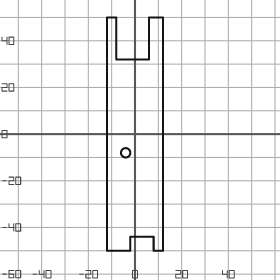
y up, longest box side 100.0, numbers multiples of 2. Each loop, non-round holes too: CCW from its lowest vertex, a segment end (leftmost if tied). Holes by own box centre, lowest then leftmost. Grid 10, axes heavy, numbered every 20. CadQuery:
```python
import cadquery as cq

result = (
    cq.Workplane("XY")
    .moveTo(-12.0, -50.0)
    .lineTo(-2.0, -50.0)
    .lineTo(-2.0, -44.0)
    .lineTo(8.0, -44.0)
    .lineTo(8.0, -50.0)
    .lineTo(12.0, -50.0)
    .lineTo(12.0, 50.0)
    .lineTo(6.0, 50.0)
    .lineTo(6.0, 32.0)
    .lineTo(-8.0, 32.0)
    .lineTo(-8.0, 50.0)
    .lineTo(-12.0, 50.0)
    .close()
    .moveTo(-4.0, -8.0)
    .circle(2.0)
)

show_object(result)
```